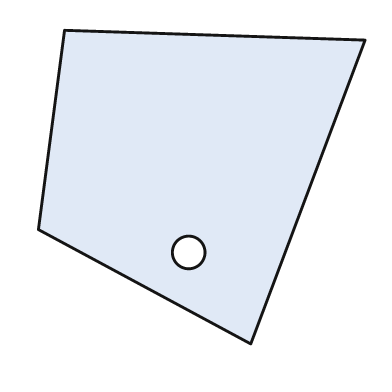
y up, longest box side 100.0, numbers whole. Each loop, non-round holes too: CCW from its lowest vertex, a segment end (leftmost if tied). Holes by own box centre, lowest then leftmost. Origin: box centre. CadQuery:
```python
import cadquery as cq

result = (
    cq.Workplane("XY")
    .moveTo(15.0, -48.0)
    .lineTo(50.0, 45.0)
    .lineTo(-42.0, 48.0)
    .lineTo(-50.0, -13.0)
    .close()
    .moveTo(-4.0, -20.0)
    .circle(5.0)
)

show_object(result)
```